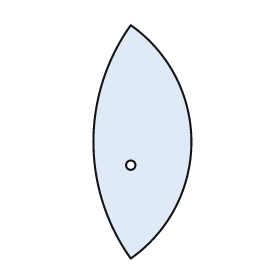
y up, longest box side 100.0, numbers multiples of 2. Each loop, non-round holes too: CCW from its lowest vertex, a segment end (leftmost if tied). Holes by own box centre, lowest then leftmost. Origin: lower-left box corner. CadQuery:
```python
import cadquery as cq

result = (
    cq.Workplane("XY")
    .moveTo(16.0, 0.0)
    .threePointArc((42.0, 50.0), (16.0, 100.0))
    .threePointArc((0.0, 50.0), (16.0, 0.0))
    .close()
    .moveTo(16.0, 40.0)
    .circle(2.0)
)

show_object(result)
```